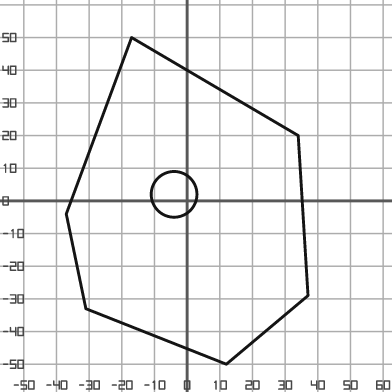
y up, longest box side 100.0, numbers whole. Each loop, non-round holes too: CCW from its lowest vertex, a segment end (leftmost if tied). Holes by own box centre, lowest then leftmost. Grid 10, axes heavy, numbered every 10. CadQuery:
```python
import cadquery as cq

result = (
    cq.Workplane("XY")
    .moveTo(12.0, -50.0)
    .lineTo(37.0, -29.0)
    .lineTo(34.0, 20.0)
    .lineTo(-17.0, 50.0)
    .lineTo(-37.0, -4.0)
    .lineTo(-31.0, -33.0)
    .close()
    .moveTo(-4.0, 2.0)
    .circle(7.0)
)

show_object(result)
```